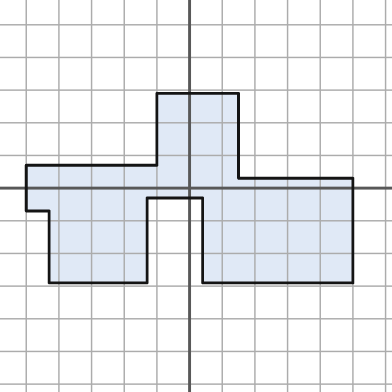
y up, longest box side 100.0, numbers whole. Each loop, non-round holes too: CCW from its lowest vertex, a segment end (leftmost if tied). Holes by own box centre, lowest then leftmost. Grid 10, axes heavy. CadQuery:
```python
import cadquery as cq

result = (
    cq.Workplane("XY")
    .moveTo(-43.0, -29.0)
    .lineTo(-13.0, -29.0)
    .lineTo(-13.0, -3.0)
    .lineTo(4.0, -3.0)
    .lineTo(4.0, -29.0)
    .lineTo(50.0, -29.0)
    .lineTo(50.0, 3.0)
    .lineTo(15.0, 3.0)
    .lineTo(15.0, 29.0)
    .lineTo(-10.0, 29.0)
    .lineTo(-10.0, 7.0)
    .lineTo(-50.0, 7.0)
    .lineTo(-50.0, -7.0)
    .lineTo(-43.0, -7.0)
    .close()
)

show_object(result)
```